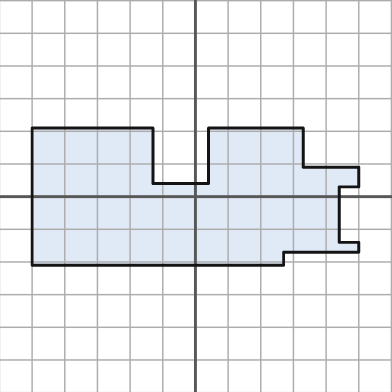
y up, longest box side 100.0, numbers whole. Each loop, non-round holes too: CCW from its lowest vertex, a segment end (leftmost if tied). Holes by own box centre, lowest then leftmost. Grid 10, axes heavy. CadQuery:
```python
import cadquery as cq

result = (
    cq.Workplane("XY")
    .moveTo(-50.0, -21.0)
    .lineTo(27.0, -21.0)
    .lineTo(27.0, -17.0)
    .lineTo(50.0, -17.0)
    .lineTo(50.0, -14.0)
    .lineTo(44.0, -14.0)
    .lineTo(44.0, 3.0)
    .lineTo(50.0, 3.0)
    .lineTo(50.0, 9.0)
    .lineTo(33.0, 9.0)
    .lineTo(33.0, 21.0)
    .lineTo(4.0, 21.0)
    .lineTo(4.0, 4.0)
    .lineTo(-13.0, 4.0)
    .lineTo(-13.0, 21.0)
    .lineTo(-50.0, 21.0)
    .close()
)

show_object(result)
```